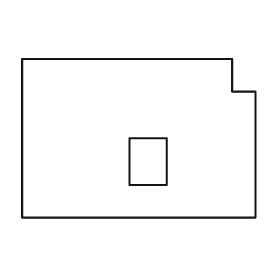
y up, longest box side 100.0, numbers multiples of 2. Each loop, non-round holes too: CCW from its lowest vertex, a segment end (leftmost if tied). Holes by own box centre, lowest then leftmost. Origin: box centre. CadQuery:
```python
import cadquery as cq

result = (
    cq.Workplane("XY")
    .moveTo(-50.0, -34.0)
    .lineTo(50.0, -34.0)
    .lineTo(50.0, 20.0)
    .lineTo(40.0, 20.0)
    .lineTo(40.0, 34.0)
    .lineTo(-50.0, 34.0)
    .close()
    .moveTo(-4.0, -20.0)
    .lineTo(12.0, -20.0)
    .lineTo(12.0, 0.0)
    .lineTo(-4.0, 0.0)
    .close()
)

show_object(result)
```